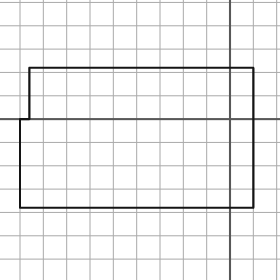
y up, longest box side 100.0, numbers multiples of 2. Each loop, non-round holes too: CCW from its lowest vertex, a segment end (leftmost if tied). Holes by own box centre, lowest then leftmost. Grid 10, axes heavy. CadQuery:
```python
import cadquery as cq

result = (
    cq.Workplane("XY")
    .moveTo(-90.0, -38.0)
    .lineTo(10.0, -38.0)
    .lineTo(10.0, 22.0)
    .lineTo(-86.0, 22.0)
    .lineTo(-86.0, 0.0)
    .lineTo(-90.0, 0.0)
    .close()
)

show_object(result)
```